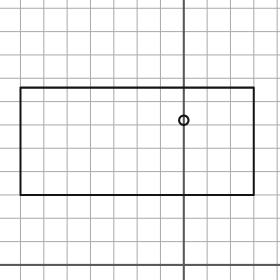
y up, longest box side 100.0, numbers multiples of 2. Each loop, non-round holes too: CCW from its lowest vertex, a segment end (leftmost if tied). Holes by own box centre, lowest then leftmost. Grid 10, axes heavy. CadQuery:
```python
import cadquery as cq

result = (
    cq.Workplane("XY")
    .moveTo(-70.0, 30.0)
    .lineTo(30.0, 30.0)
    .lineTo(30.0, 76.0)
    .lineTo(-70.0, 76.0)
    .close()
    .moveTo(0.0, 62.0)
    .circle(2.0)
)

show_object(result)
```